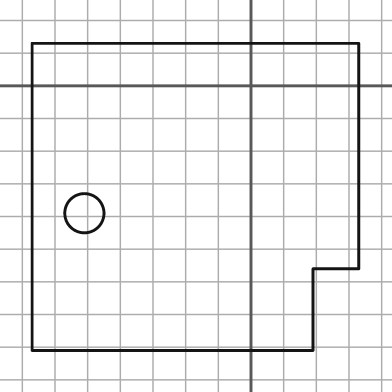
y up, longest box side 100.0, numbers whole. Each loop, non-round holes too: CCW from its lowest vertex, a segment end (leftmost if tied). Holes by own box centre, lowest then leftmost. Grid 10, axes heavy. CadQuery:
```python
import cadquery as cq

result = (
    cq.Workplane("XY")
    .moveTo(-67.0, -81.0)
    .lineTo(19.0, -81.0)
    .lineTo(19.0, -56.0)
    .lineTo(33.0, -56.0)
    .lineTo(33.0, 13.0)
    .lineTo(-67.0, 13.0)
    .close()
    .moveTo(-51.0, -39.0)
    .circle(6.0)
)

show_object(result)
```